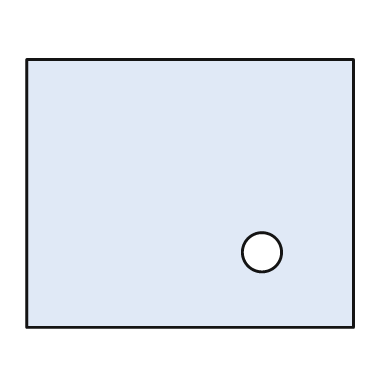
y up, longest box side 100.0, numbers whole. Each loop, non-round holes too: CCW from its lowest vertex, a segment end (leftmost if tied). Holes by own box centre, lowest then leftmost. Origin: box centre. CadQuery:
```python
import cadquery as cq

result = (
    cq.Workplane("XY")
    .moveTo(-50.0, -41.0)
    .lineTo(50.0, -41.0)
    .lineTo(50.0, 41.0)
    .lineTo(-50.0, 41.0)
    .close()
    .moveTo(22.0, -18.0)
    .circle(6.0)
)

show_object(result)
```